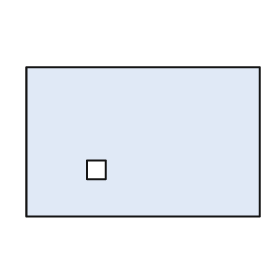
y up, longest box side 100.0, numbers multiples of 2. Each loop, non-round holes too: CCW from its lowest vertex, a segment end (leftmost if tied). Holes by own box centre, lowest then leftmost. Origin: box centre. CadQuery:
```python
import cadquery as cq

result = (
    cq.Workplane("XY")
    .moveTo(-50.0, -32.0)
    .lineTo(50.0, -32.0)
    .lineTo(50.0, 32.0)
    .lineTo(-50.0, 32.0)
    .close()
    .moveTo(-24.0, -16.0)
    .lineTo(-16.0, -16.0)
    .lineTo(-16.0, -8.0)
    .lineTo(-24.0, -8.0)
    .close()
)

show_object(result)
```